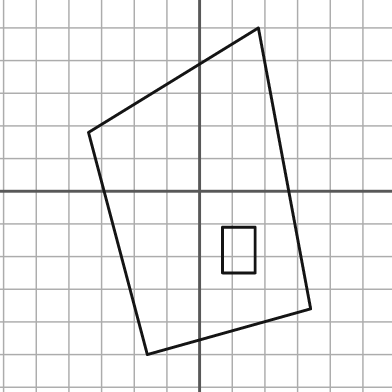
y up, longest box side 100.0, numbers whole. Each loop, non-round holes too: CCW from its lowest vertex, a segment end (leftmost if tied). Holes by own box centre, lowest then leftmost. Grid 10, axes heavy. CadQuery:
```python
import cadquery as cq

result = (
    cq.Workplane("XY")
    .moveTo(-16.0, -50.0)
    .lineTo(34.0, -36.0)
    .lineTo(18.0, 50.0)
    .lineTo(-34.0, 18.0)
    .close()
    .moveTo(7.0, -25.0)
    .lineTo(17.0, -25.0)
    .lineTo(17.0, -11.0)
    .lineTo(7.0, -11.0)
    .close()
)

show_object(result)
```